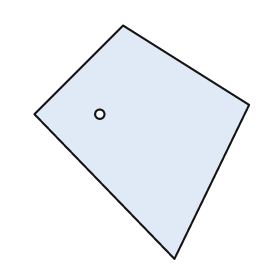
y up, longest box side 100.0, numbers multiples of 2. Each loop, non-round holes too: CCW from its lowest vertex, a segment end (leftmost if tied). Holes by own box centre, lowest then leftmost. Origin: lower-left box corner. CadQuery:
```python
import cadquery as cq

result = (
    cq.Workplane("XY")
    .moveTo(60.0, 0.0)
    .lineTo(92.0, 66.0)
    .lineTo(38.0, 100.0)
    .lineTo(0.0, 62.0)
    .close()
    .moveTo(28.0, 62.0)
    .circle(2.0)
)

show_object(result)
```